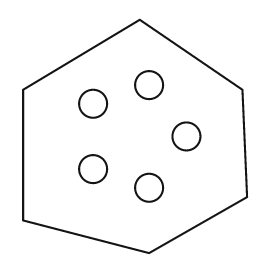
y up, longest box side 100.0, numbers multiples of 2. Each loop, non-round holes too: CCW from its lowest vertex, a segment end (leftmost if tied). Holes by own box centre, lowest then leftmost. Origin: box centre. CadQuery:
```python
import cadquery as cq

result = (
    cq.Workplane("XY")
    .moveTo(6.0, -50.0)
    .lineTo(48.0, -26.0)
    .lineTo(46.0, 20.0)
    .lineTo(2.0, 50.0)
    .lineTo(-48.0, 20.0)
    .lineTo(-48.0, -36.0)
    .close()
    .moveTo(6.0, -22.0)
    .circle(6.0)
    .moveTo(-18.0, -14.0)
    .circle(6.0)
    .moveTo(22.0, 0.0)
    .circle(6.0)
    .moveTo(-18.0, 14.0)
    .circle(6.0)
    .moveTo(6.0, 22.0)
    .circle(6.0)
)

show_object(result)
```